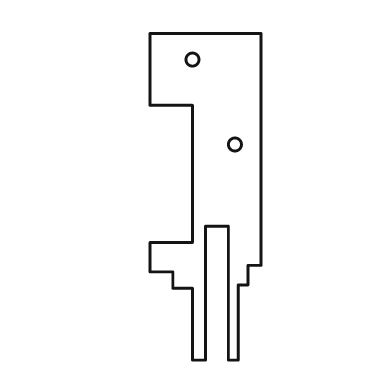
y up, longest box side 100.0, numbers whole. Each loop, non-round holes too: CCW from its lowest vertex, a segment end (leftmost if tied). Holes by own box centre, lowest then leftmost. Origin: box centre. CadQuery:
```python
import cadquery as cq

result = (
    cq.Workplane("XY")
    .moveTo(-4.0, -50.0)
    .lineTo(0.0, -50.0)
    .lineTo(0.0, -9.0)
    .lineTo(7.0, -9.0)
    .lineTo(7.0, -50.0)
    .lineTo(10.0, -50.0)
    .lineTo(10.0, -27.0)
    .lineTo(13.0, -27.0)
    .lineTo(13.0, -21.0)
    .lineTo(17.0, -21.0)
    .lineTo(17.0, 50.0)
    .lineTo(-17.0, 50.0)
    .lineTo(-17.0, 28.0)
    .lineTo(-4.0, 28.0)
    .lineTo(-4.0, -14.0)
    .lineTo(-17.0, -14.0)
    .lineTo(-17.0, -23.0)
    .lineTo(-10.0, -23.0)
    .lineTo(-10.0, -28.0)
    .lineTo(-4.0, -28.0)
    .close()
    .moveTo(9.0, 16.0)
    .circle(2.0)
    .moveTo(-4.0, 42.0)
    .circle(2.0)
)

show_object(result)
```